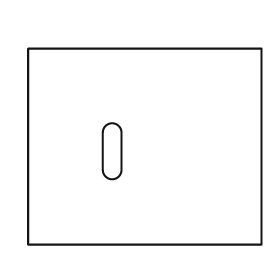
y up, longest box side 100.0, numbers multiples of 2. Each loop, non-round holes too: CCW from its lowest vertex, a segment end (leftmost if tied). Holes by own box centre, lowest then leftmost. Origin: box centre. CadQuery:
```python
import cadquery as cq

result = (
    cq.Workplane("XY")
    .moveTo(-50.0, -42.0)
    .lineTo(50.0, -42.0)
    .lineTo(50.0, 42.0)
    .lineTo(-50.0, 42.0)
    .close()
    .moveTo(-18.0, -10.0)
    .threePointArc((-14.0, -14.0), (-10.0, -10.0))
    .lineTo(-10.0, 6.0)
    .threePointArc((-14.0, 10.0), (-18.0, 6.0))
    .close()
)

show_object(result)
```